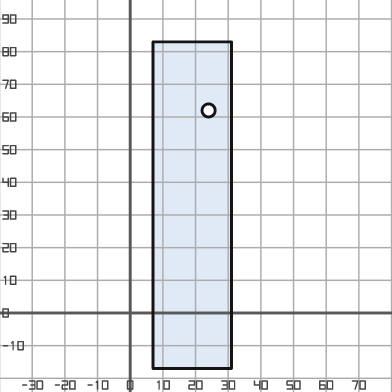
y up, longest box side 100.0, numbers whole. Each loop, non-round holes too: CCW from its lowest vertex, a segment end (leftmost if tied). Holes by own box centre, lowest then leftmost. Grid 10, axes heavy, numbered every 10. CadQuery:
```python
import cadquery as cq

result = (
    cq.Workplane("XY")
    .moveTo(7.0, -17.0)
    .lineTo(31.0, -17.0)
    .lineTo(31.0, 83.0)
    .lineTo(7.0, 83.0)
    .close()
    .moveTo(24.0, 62.0)
    .circle(2.0)
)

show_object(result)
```